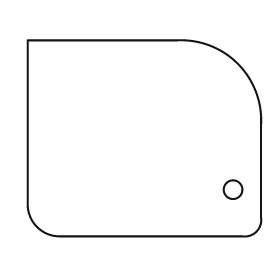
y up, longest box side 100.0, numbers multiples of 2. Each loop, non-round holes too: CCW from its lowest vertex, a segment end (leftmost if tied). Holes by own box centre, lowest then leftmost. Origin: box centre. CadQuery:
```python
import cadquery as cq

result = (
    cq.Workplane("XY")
    .moveTo(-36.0, -42.0)
    .lineTo(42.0, -42.0)
    .threePointArc((48.0, -40.0), (50.0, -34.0))
    .lineTo(50.0, 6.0)
    .threePointArc((40.0, 32.0), (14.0, 42.0))
    .lineTo(-50.0, 42.0)
    .lineTo(-50.0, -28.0)
    .threePointArc((-46.0, -38.0), (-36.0, -42.0))
    .close()
    .moveTo(38.0, -22.0)
    .circle(4.0)
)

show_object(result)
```